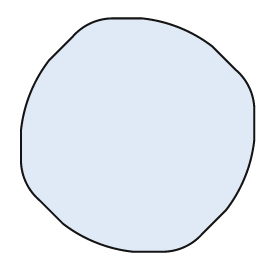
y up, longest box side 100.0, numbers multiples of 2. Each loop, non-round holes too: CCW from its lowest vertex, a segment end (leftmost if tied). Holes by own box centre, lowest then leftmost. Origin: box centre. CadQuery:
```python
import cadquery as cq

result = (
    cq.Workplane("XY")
    .moveTo(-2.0, -50.0)
    .lineTo(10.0, -50.0)
    .threePointArc((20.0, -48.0), (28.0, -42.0))
    .lineTo(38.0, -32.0)
    .threePointArc((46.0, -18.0), (50.0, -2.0))
    .lineTo(50.0, 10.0)
    .threePointArc((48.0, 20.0), (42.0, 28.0))
    .lineTo(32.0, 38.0)
    .threePointArc((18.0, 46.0), (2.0, 50.0))
    .lineTo(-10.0, 50.0)
    .threePointArc((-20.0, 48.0), (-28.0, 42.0))
    .lineTo(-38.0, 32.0)
    .threePointArc((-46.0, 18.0), (-50.0, 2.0))
    .lineTo(-50.0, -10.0)
    .threePointArc((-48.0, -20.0), (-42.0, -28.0))
    .lineTo(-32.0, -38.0)
    .threePointArc((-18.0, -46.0), (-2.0, -50.0))
    .close()
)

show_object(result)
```